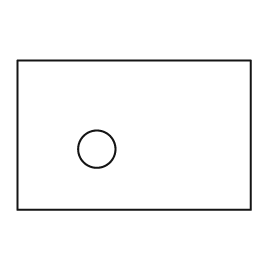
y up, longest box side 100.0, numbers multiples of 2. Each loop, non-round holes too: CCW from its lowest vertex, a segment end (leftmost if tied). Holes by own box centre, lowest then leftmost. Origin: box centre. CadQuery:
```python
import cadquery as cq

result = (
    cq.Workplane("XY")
    .moveTo(-50.0, -32.0)
    .lineTo(50.0, -32.0)
    .lineTo(50.0, 32.0)
    .lineTo(-50.0, 32.0)
    .close()
    .moveTo(-16.0, -6.0)
    .circle(8.0)
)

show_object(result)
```